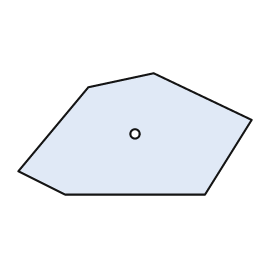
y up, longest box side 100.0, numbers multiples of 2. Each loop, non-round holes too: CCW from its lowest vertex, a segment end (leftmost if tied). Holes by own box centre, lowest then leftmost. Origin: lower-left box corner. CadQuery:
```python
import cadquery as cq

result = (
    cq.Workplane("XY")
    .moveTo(20.0, 0.0)
    .lineTo(80.0, 0.0)
    .lineTo(100.0, 32.0)
    .lineTo(58.0, 52.0)
    .lineTo(30.0, 46.0)
    .lineTo(0.0, 10.0)
    .close()
    .moveTo(50.0, 26.0)
    .circle(2.0)
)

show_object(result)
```